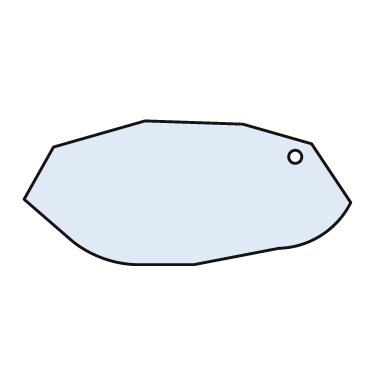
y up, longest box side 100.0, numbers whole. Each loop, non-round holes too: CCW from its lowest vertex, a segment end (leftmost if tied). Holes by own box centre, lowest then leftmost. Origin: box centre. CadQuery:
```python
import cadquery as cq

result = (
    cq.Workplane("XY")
    .moveTo(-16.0, -22.0)
    .lineTo(2.0, -22.0)
    .lineTo(28.0, -17.0)
    .threePointArc((41.0, -13.0), (50.0, -3.0))
    .lineTo(38.0, 15.0)
    .lineTo(17.0, 21.0)
    .lineTo(-13.0, 22.0)
    .lineTo(-41.0, 14.0)
    .lineTo(-50.0, -2.0)
    .lineTo(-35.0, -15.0)
    .threePointArc((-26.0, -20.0), (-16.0, -22.0))
    .close()
    .moveTo(33.0, 11.0)
    .circle(2.0)
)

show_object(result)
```